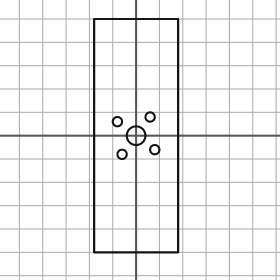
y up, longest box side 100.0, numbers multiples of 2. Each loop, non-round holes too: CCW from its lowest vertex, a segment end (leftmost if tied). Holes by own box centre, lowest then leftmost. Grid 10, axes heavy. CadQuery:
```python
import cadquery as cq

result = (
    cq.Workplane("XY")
    .moveTo(-18.0, -50.0)
    .lineTo(18.0, -50.0)
    .lineTo(18.0, 50.0)
    .lineTo(-18.0, 50.0)
    .close()
    .moveTo(-6.0, -8.0)
    .circle(2.0)
    .moveTo(8.0, -6.0)
    .circle(2.0)
    .moveTo(0.0, 0.0)
    .circle(4.0)
    .moveTo(-8.0, 6.0)
    .circle(2.0)
    .moveTo(6.0, 8.0)
    .circle(2.0)
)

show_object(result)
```